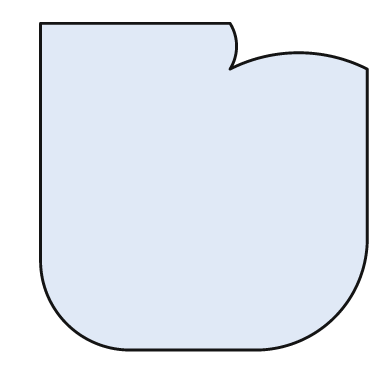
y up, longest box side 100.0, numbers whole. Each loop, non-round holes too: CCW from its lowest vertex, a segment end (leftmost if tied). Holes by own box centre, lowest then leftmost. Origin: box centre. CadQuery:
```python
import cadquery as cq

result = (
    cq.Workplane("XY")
    .moveTo(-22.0, -50.0)
    .lineTo(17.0, -50.0)
    .threePointArc((40.0, -40.0), (50.0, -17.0))
    .lineTo(50.0, 36.0)
    .threePointArc((29.0, 41.0), (8.0, 36.0))
    .threePointArc((10.0, 43.0), (8.0, 50.0))
    .lineTo(-50.0, 50.0)
    .lineTo(-50.0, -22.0)
    .threePointArc((-42.0, -42.0), (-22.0, -50.0))
    .close()
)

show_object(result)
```